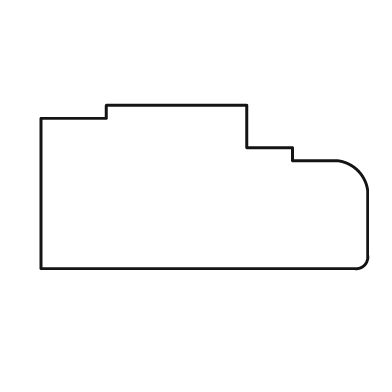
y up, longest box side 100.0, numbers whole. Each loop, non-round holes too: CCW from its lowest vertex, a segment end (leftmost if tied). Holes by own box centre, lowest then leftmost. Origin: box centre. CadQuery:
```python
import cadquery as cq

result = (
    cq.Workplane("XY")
    .moveTo(-50.0, -25.0)
    .lineTo(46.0, -25.0)
    .threePointArc((49.0, -24.0), (50.0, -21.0))
    .lineTo(50.0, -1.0)
    .threePointArc((47.0, 5.0), (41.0, 8.0))
    .lineTo(27.0, 8.0)
    .lineTo(27.0, 12.0)
    .lineTo(13.0, 12.0)
    .lineTo(13.0, 25.0)
    .lineTo(-30.0, 25.0)
    .lineTo(-30.0, 21.0)
    .lineTo(-50.0, 21.0)
    .close()
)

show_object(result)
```